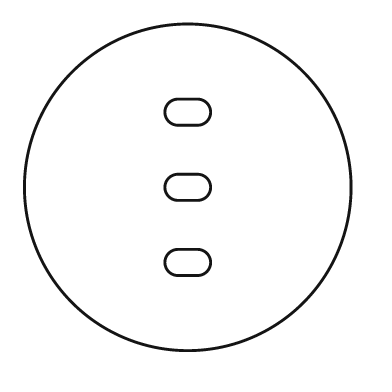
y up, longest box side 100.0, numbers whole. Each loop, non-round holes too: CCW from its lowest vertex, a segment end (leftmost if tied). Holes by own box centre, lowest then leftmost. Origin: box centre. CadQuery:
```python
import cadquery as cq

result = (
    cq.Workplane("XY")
    .moveTo(0.0, 0.0)
    .circle(50.0)
    .moveTo(-3.0, -27.0)
    .lineTo(3.0, -27.0)
    .threePointArc((7.0, -23.0), (3.0, -19.0))
    .lineTo(-3.0, -19.0)
    .threePointArc((-7.0, -23.0), (-3.0, -27.0))
    .close()
    .moveTo(-3.0, -4.0)
    .lineTo(3.0, -4.0)
    .threePointArc((7.0, 0.0), (3.0, 4.0))
    .lineTo(-3.0, 4.0)
    .threePointArc((-7.0, 0.0), (-3.0, -4.0))
    .close()
    .moveTo(-3.0, 19.0)
    .lineTo(3.0, 19.0)
    .threePointArc((7.0, 23.0), (3.0, 27.0))
    .lineTo(-3.0, 27.0)
    .threePointArc((-7.0, 23.0), (-3.0, 19.0))
    .close()
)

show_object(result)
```